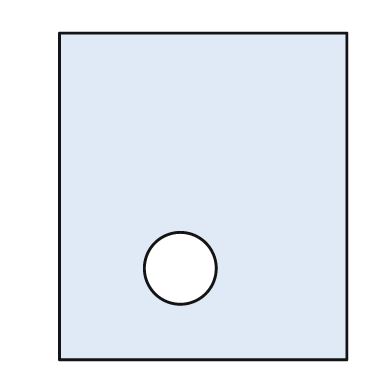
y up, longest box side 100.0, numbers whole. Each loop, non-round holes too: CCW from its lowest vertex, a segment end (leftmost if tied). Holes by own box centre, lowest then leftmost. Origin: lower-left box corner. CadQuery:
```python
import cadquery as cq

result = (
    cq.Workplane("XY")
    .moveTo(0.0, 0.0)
    .lineTo(88.0, 0.0)
    .lineTo(88.0, 100.0)
    .lineTo(0.0, 100.0)
    .close()
    .moveTo(37.0, 28.0)
    .circle(11.0)
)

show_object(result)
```